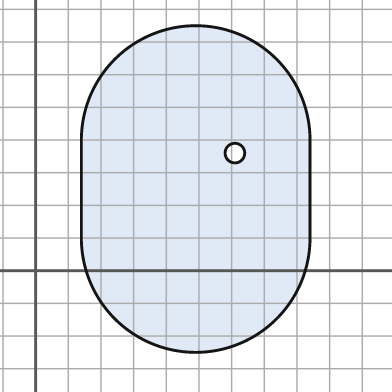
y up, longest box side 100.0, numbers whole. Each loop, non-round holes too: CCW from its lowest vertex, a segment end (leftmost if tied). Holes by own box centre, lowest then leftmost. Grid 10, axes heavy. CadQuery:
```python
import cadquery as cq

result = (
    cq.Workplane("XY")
    .moveTo(14.0, 10.0)
    .threePointArc((49.0, -25.0), (84.0, 10.0))
    .lineTo(84.0, 40.0)
    .threePointArc((49.0, 75.0), (14.0, 40.0))
    .close()
    .moveTo(61.0, 36.0)
    .circle(3.0)
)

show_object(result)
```